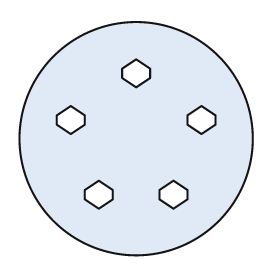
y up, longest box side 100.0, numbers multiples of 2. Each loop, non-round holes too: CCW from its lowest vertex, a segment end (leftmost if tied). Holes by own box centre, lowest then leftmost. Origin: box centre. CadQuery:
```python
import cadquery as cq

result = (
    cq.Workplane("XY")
    .moveTo(0.0, 0.0)
    .circle(50.0)
    .moveTo(-16.0, -30.0)
    .lineTo(-10.0, -26.0)
    .lineTo(-10.0, -22.0)
    .lineTo(-16.0, -18.0)
    .lineTo(-22.0, -22.0)
    .lineTo(-22.0, -26.0)
    .close()
    .moveTo(16.0, -30.0)
    .lineTo(22.0, -26.0)
    .lineTo(22.0, -22.0)
    .lineTo(16.0, -18.0)
    .lineTo(10.0, -22.0)
    .lineTo(10.0, -26.0)
    .close()
    .moveTo(-28.0, 2.0)
    .lineTo(-22.0, 6.0)
    .lineTo(-22.0, 10.0)
    .lineTo(-28.0, 14.0)
    .lineTo(-34.0, 10.0)
    .lineTo(-34.0, 6.0)
    .close()
    .moveTo(28.0, 2.0)
    .lineTo(34.0, 6.0)
    .lineTo(34.0, 10.0)
    .lineTo(28.0, 14.0)
    .lineTo(22.0, 10.0)
    .lineTo(22.0, 6.0)
    .close()
    .moveTo(0.0, 22.0)
    .lineTo(6.0, 26.0)
    .lineTo(6.0, 30.0)
    .lineTo(0.0, 34.0)
    .lineTo(-6.0, 30.0)
    .lineTo(-6.0, 26.0)
    .close()
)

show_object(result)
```